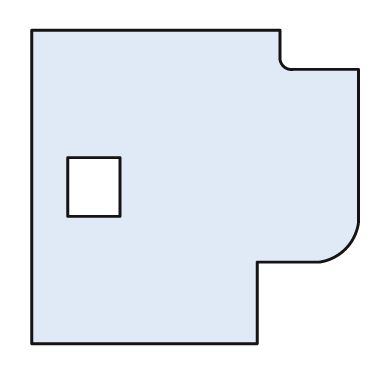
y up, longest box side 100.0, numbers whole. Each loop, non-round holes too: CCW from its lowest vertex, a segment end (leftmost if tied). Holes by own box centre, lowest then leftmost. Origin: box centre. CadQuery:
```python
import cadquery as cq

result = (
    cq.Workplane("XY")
    .moveTo(-50.0, -48.0)
    .lineTo(19.0, -48.0)
    .lineTo(19.0, -23.0)
    .lineTo(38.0, -23.0)
    .threePointArc((46.0, -19.0), (50.0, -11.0))
    .lineTo(50.0, 36.0)
    .lineTo(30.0, 36.0)
    .threePointArc((27.0, 37.0), (26.0, 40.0))
    .lineTo(26.0, 48.0)
    .lineTo(-50.0, 48.0)
    .close()
    .moveTo(-39.0, -9.0)
    .lineTo(-23.0, -9.0)
    .lineTo(-23.0, 9.0)
    .lineTo(-39.0, 9.0)
    .close()
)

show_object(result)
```